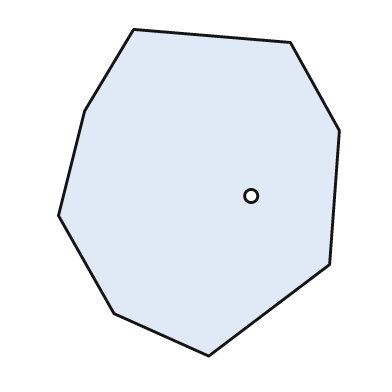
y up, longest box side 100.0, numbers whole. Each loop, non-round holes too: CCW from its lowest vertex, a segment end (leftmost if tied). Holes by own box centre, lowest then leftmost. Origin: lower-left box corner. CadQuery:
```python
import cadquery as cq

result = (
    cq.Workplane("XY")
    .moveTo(46.0, 0.0)
    .lineTo(83.0, 28.0)
    .lineTo(86.0, 69.0)
    .lineTo(71.0, 96.0)
    .lineTo(23.0, 100.0)
    .lineTo(8.0, 75.0)
    .lineTo(0.0, 43.0)
    .lineTo(17.0, 13.0)
    .close()
    .moveTo(59.0, 49.0)
    .circle(2.0)
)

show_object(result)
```